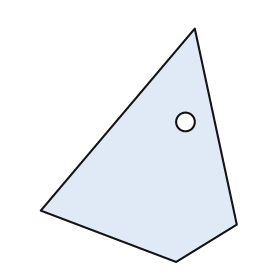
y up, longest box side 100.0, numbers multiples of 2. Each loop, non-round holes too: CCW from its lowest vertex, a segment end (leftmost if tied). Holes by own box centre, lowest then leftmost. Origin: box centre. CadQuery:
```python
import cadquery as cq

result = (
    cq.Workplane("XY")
    .moveTo(16.0, -50.0)
    .lineTo(42.0, -34.0)
    .lineTo(24.0, 50.0)
    .lineTo(-42.0, -28.0)
    .close()
    .moveTo(20.0, 10.0)
    .circle(4.0)
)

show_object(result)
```